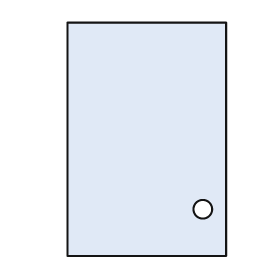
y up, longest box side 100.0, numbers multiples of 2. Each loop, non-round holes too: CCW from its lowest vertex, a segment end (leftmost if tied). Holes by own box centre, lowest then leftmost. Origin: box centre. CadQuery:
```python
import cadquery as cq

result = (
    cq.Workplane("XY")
    .moveTo(-34.0, -50.0)
    .lineTo(34.0, -50.0)
    .lineTo(34.0, 50.0)
    .lineTo(-34.0, 50.0)
    .close()
    .moveTo(24.0, -30.0)
    .circle(4.0)
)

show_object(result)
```